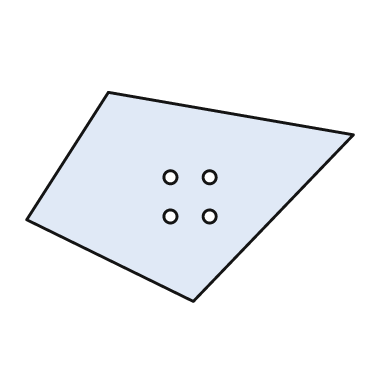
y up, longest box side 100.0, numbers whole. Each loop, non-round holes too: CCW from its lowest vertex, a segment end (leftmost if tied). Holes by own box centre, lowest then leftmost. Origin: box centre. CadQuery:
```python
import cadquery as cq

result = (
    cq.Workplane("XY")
    .moveTo(1.0, -32.0)
    .lineTo(50.0, 19.0)
    .lineTo(-25.0, 32.0)
    .lineTo(-50.0, -7.0)
    .close()
    .moveTo(-6.0, -6.0)
    .circle(2.0)
    .moveTo(6.0, -6.0)
    .circle(2.0)
    .moveTo(-6.0, 6.0)
    .circle(2.0)
    .moveTo(6.0, 6.0)
    .circle(2.0)
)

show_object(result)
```